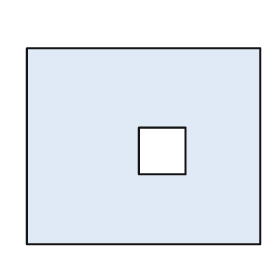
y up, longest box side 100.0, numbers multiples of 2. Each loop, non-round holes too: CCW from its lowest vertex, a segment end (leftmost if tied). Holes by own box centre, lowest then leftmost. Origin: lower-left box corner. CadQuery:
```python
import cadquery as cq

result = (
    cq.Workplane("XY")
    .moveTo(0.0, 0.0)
    .lineTo(100.0, 0.0)
    .lineTo(100.0, 84.0)
    .lineTo(0.0, 84.0)
    .close()
    .moveTo(48.0, 30.0)
    .lineTo(68.0, 30.0)
    .lineTo(68.0, 50.0)
    .lineTo(48.0, 50.0)
    .close()
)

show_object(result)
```